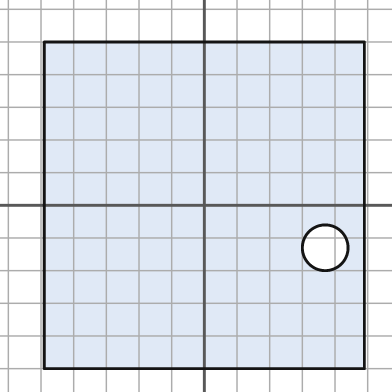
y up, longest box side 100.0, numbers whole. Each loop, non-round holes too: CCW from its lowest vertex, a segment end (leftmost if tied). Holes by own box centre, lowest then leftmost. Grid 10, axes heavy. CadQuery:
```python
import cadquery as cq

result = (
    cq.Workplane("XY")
    .moveTo(-49.0, -50.0)
    .lineTo(49.0, -50.0)
    .lineTo(49.0, 50.0)
    .lineTo(-49.0, 50.0)
    .close()
    .moveTo(37.0, -13.0)
    .circle(7.0)
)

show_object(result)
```